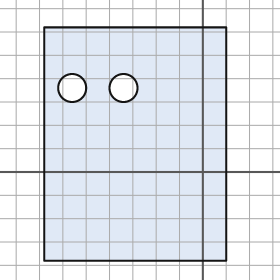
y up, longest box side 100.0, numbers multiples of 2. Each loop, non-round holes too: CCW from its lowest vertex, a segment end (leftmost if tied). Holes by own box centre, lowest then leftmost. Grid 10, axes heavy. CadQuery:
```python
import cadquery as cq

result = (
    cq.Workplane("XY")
    .moveTo(-68.0, -38.0)
    .lineTo(10.0, -38.0)
    .lineTo(10.0, 62.0)
    .lineTo(-68.0, 62.0)
    .close()
    .moveTo(-56.0, 36.0)
    .circle(6.0)
    .moveTo(-34.0, 36.0)
    .circle(6.0)
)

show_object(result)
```